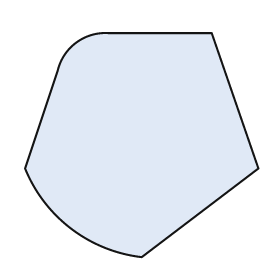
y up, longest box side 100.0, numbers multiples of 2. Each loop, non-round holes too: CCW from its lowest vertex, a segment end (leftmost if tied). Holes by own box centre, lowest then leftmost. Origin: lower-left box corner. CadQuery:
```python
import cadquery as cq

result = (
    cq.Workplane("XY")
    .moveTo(50.0, 0.0)
    .lineTo(100.0, 38.0)
    .lineTo(80.0, 96.0)
    .lineTo(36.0, 96.0)
    .threePointArc((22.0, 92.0), (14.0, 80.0))
    .lineTo(0.0, 38.0)
    .threePointArc((20.0, 12.0), (50.0, 0.0))
    .close()
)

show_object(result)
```